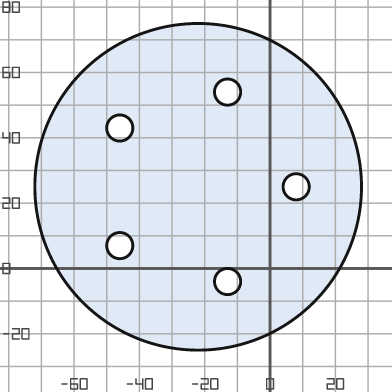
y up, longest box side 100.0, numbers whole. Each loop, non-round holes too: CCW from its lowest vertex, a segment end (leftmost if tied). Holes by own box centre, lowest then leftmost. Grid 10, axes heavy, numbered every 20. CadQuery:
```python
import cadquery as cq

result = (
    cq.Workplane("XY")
    .moveTo(-22.0, 25.0)
    .circle(50.0)
    .moveTo(-13.0, -4.0)
    .circle(4.0)
    .moveTo(-46.0, 7.0)
    .circle(4.0)
    .moveTo(8.0, 25.0)
    .circle(4.0)
    .moveTo(-46.0, 43.0)
    .circle(4.0)
    .moveTo(-13.0, 54.0)
    .circle(4.0)
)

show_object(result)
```